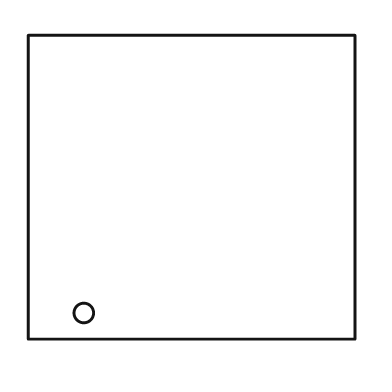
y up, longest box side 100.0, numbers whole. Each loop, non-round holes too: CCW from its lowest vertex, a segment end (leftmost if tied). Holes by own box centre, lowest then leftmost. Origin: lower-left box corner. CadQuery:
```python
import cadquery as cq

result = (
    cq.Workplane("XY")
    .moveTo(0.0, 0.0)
    .lineTo(100.0, 0.0)
    .lineTo(100.0, 93.0)
    .lineTo(0.0, 93.0)
    .close()
    .moveTo(17.0, 8.0)
    .circle(3.0)
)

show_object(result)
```